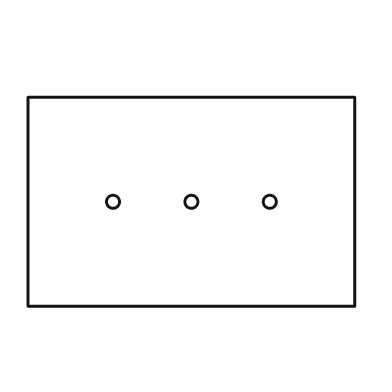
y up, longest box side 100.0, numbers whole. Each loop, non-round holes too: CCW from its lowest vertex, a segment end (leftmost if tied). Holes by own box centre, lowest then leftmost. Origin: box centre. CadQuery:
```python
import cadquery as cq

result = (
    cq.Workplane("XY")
    .moveTo(-50.0, -32.0)
    .lineTo(50.0, -32.0)
    .lineTo(50.0, 32.0)
    .lineTo(-50.0, 32.0)
    .close()
    .moveTo(-24.0, 0.0)
    .circle(2.0)
    .moveTo(0.0, 0.0)
    .circle(2.0)
    .moveTo(24.0, 0.0)
    .circle(2.0)
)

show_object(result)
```